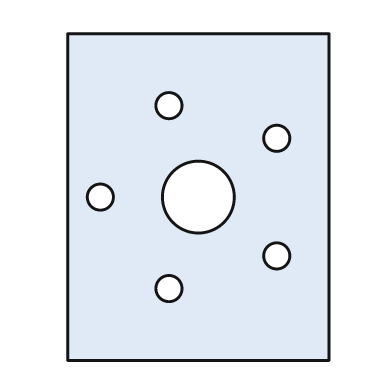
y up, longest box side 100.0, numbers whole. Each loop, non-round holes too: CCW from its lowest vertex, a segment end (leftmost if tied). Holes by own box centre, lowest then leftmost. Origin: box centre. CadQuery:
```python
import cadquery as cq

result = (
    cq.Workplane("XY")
    .moveTo(-40.0, -50.0)
    .lineTo(40.0, -50.0)
    .lineTo(40.0, 50.0)
    .lineTo(-40.0, 50.0)
    .close()
    .moveTo(-9.0, -28.0)
    .circle(4.0)
    .moveTo(24.0, -18.0)
    .circle(4.0)
    .moveTo(-30.0, 0.0)
    .circle(4.0)
    .moveTo(0.0, 0.0)
    .circle(11.0)
    .moveTo(24.0, 18.0)
    .circle(4.0)
    .moveTo(-9.0, 28.0)
    .circle(4.0)
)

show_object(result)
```